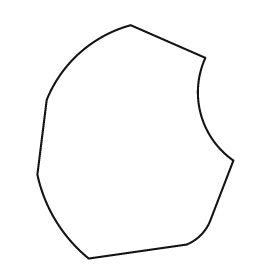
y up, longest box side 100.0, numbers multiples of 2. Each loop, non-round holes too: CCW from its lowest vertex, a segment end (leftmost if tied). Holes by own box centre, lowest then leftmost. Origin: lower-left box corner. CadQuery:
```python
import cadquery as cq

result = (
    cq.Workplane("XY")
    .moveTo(22.0, 0.0)
    .lineTo(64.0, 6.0)
    .threePointArc((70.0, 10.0), (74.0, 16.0))
    .lineTo(84.0, 42.0)
    .threePointArc((70.0, 62.0), (72.0, 86.0))
    .lineTo(40.0, 100.0)
    .threePointArc((18.0, 88.0), (4.0, 68.0))
    .lineTo(0.0, 36.0)
    .threePointArc((8.0, 16.0), (22.0, 0.0))
    .close()
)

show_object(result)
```